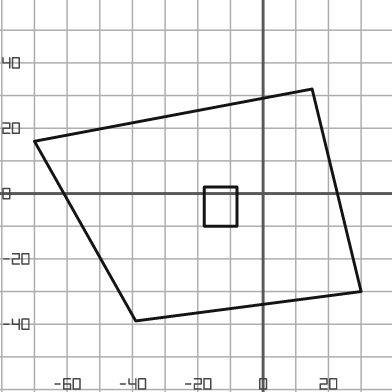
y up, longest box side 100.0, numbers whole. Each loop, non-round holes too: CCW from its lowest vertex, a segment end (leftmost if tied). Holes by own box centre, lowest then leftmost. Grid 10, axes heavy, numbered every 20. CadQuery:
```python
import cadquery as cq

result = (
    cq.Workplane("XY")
    .moveTo(-39.0, -39.0)
    .lineTo(30.0, -30.0)
    .lineTo(15.0, 32.0)
    .lineTo(-70.0, 16.0)
    .close()
    .moveTo(-18.0, -10.0)
    .lineTo(-8.0, -10.0)
    .lineTo(-8.0, 2.0)
    .lineTo(-18.0, 2.0)
    .close()
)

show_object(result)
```